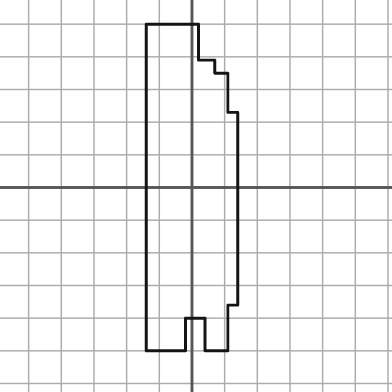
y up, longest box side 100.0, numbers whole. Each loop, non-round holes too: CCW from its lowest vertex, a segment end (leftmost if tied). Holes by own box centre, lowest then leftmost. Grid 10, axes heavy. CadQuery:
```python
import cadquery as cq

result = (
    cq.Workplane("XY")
    .moveTo(-14.0, -50.0)
    .lineTo(-2.0, -50.0)
    .lineTo(-2.0, -40.0)
    .lineTo(4.0, -40.0)
    .lineTo(4.0, -50.0)
    .lineTo(11.0, -50.0)
    .lineTo(11.0, -36.0)
    .lineTo(14.0, -36.0)
    .lineTo(14.0, 23.0)
    .lineTo(11.0, 23.0)
    .lineTo(11.0, 35.0)
    .lineTo(7.0, 35.0)
    .lineTo(7.0, 39.0)
    .lineTo(2.0, 39.0)
    .lineTo(2.0, 50.0)
    .lineTo(-14.0, 50.0)
    .close()
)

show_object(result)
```